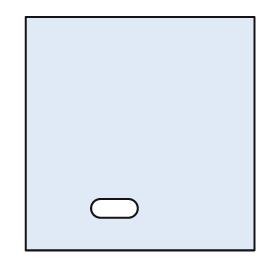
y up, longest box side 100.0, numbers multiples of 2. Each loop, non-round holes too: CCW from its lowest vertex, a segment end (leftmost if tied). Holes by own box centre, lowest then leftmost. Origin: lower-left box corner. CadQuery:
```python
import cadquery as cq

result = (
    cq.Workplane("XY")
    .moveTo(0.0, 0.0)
    .lineTo(98.0, 0.0)
    .lineTo(98.0, 100.0)
    .lineTo(0.0, 100.0)
    .close()
    .moveTo(32.0, 14.0)
    .lineTo(44.0, 14.0)
    .threePointArc((48.0, 18.0), (44.0, 22.0))
    .lineTo(32.0, 22.0)
    .threePointArc((28.0, 18.0), (32.0, 14.0))
    .close()
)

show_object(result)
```